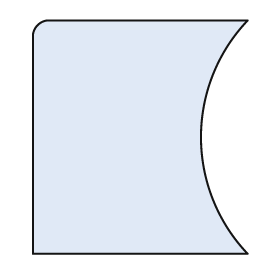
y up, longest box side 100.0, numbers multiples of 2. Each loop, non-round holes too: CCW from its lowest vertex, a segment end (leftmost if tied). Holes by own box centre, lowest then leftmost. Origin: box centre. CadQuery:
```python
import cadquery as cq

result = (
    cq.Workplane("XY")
    .moveTo(-46.0, -50.0)
    .lineTo(46.0, -50.0)
    .threePointArc((26.0, 0.0), (46.0, 50.0))
    .lineTo(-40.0, 50.0)
    .threePointArc((-44.0, 48.0), (-46.0, 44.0))
    .close()
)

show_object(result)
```